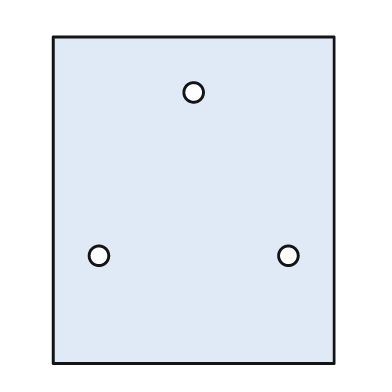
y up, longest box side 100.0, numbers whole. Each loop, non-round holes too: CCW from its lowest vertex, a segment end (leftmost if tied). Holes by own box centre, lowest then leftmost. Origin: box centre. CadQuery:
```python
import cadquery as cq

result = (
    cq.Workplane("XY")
    .moveTo(-43.0, -50.0)
    .lineTo(43.0, -50.0)
    .lineTo(43.0, 50.0)
    .lineTo(-43.0, 50.0)
    .close()
    .moveTo(-29.0, -17.0)
    .circle(3.0)
    .moveTo(29.0, -17.0)
    .circle(3.0)
    .moveTo(0.0, 33.0)
    .circle(3.0)
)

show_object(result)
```